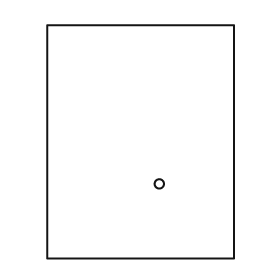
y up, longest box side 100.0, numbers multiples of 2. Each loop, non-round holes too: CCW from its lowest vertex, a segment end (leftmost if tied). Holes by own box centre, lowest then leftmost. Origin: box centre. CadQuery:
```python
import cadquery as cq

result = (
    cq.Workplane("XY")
    .moveTo(-40.0, -50.0)
    .lineTo(40.0, -50.0)
    .lineTo(40.0, 50.0)
    .lineTo(-40.0, 50.0)
    .close()
    .moveTo(8.0, -18.0)
    .circle(2.0)
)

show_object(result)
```